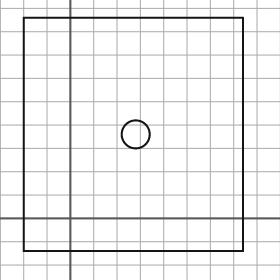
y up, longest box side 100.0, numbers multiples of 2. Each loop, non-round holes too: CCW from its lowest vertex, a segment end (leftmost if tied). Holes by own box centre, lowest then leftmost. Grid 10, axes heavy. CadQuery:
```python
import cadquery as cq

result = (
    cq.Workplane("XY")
    .moveTo(-20.0, -14.0)
    .lineTo(74.0, -14.0)
    .lineTo(74.0, 86.0)
    .lineTo(-20.0, 86.0)
    .close()
    .moveTo(28.0, 36.0)
    .circle(6.0)
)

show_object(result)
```